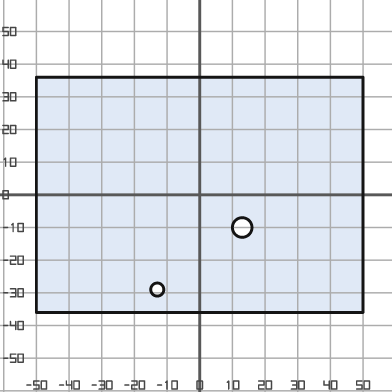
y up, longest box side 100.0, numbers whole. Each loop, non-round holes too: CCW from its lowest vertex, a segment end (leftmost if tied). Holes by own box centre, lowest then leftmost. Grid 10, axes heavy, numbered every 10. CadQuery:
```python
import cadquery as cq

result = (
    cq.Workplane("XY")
    .moveTo(-50.0, -36.0)
    .lineTo(50.0, -36.0)
    .lineTo(50.0, 36.0)
    .lineTo(-50.0, 36.0)
    .close()
    .moveTo(-13.0, -29.0)
    .circle(2.0)
    .moveTo(13.0, -10.0)
    .circle(3.0)
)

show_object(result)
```